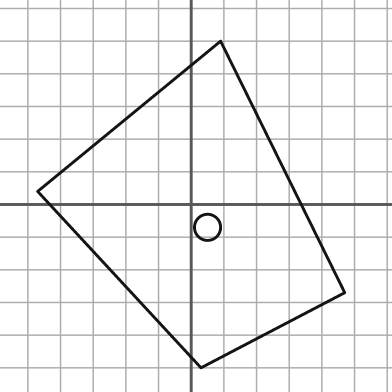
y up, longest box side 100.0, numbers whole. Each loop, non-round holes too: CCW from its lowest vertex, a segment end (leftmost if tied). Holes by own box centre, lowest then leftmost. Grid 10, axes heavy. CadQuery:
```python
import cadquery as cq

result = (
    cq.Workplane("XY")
    .moveTo(3.0, -50.0)
    .lineTo(47.0, -27.0)
    .lineTo(9.0, 50.0)
    .lineTo(-47.0, 4.0)
    .close()
    .moveTo(5.0, -7.0)
    .circle(4.0)
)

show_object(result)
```